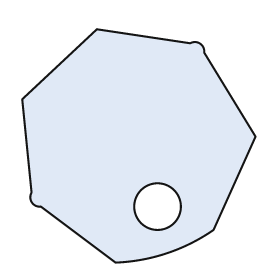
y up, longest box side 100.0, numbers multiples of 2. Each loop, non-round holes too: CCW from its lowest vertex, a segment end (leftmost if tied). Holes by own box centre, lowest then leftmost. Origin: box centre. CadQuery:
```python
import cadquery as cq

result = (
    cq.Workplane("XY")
    .moveTo(-10.0, -50.0)
    .threePointArc((12.0, -46.0), (32.0, -36.0))
    .lineTo(50.0, 4.0)
    .lineTo(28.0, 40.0)
    .threePointArc((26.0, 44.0), (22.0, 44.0))
    .lineTo(-18.0, 50.0)
    .lineTo(-50.0, 20.0)
    .lineTo(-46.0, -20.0)
    .threePointArc((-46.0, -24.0), (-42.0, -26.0))
    .close()
    .moveTo(8.0, -26.0)
    .circle(10.0)
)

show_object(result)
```